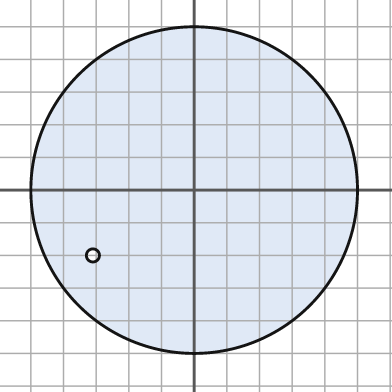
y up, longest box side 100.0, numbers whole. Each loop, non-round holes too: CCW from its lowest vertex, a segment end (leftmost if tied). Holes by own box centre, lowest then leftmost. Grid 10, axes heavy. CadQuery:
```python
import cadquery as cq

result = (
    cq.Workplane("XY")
    .moveTo(0.0, 0.0)
    .circle(50.0)
    .moveTo(-31.0, -20.0)
    .circle(2.0)
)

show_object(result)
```